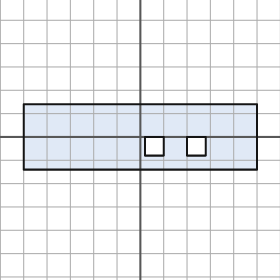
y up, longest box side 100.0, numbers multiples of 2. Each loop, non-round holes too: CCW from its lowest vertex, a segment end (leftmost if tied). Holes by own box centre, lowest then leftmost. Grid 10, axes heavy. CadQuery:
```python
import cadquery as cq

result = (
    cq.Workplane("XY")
    .moveTo(-50.0, -14.0)
    .lineTo(50.0, -14.0)
    .lineTo(50.0, 14.0)
    .lineTo(-50.0, 14.0)
    .close()
    .moveTo(2.0, -8.0)
    .lineTo(10.0, -8.0)
    .lineTo(10.0, 0.0)
    .lineTo(2.0, 0.0)
    .close()
    .moveTo(20.0, -8.0)
    .lineTo(28.0, -8.0)
    .lineTo(28.0, 0.0)
    .lineTo(20.0, 0.0)
    .close()
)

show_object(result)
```